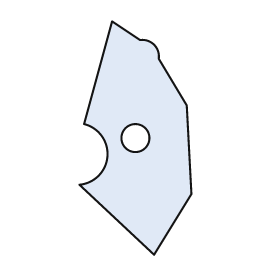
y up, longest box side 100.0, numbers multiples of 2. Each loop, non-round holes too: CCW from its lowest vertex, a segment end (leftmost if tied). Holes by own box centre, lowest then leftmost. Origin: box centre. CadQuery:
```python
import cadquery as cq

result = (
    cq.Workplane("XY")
    .moveTo(8.0, -50.0)
    .lineTo(24.0, -24.0)
    .lineTo(22.0, 14.0)
    .lineTo(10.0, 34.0)
    .threePointArc((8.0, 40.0), (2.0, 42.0))
    .lineTo(-10.0, 50.0)
    .lineTo(-22.0, 6.0)
    .threePointArc((-12.0, -8.0), (-24.0, -20.0))
    .close()
    .moveTo(0.0, 0.0)
    .circle(6.0)
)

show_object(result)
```